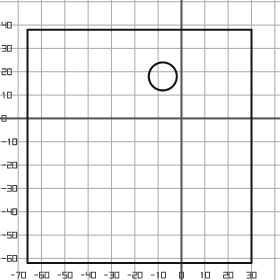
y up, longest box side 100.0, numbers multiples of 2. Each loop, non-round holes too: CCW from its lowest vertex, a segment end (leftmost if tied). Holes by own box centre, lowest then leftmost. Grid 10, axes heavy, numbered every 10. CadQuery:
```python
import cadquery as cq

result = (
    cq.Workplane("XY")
    .moveTo(-66.0, -62.0)
    .lineTo(30.0, -62.0)
    .lineTo(30.0, 38.0)
    .lineTo(-66.0, 38.0)
    .close()
    .moveTo(-8.0, 18.0)
    .circle(6.0)
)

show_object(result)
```